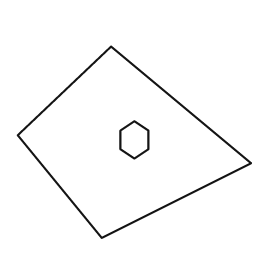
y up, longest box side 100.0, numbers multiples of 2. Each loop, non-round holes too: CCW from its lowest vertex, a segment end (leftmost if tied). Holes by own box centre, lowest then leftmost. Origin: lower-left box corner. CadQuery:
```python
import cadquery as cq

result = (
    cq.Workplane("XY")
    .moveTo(36.0, 0.0)
    .lineTo(100.0, 32.0)
    .lineTo(40.0, 82.0)
    .lineTo(0.0, 44.0)
    .close()
    .moveTo(50.0, 34.0)
    .lineTo(56.0, 38.0)
    .lineTo(56.0, 46.0)
    .lineTo(50.0, 50.0)
    .lineTo(44.0, 46.0)
    .lineTo(44.0, 38.0)
    .close()
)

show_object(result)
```